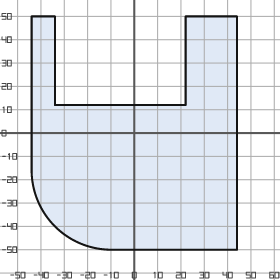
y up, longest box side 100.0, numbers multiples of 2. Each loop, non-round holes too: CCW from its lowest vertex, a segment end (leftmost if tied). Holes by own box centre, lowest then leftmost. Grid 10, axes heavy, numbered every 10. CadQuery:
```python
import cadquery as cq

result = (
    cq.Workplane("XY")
    .moveTo(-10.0, -50.0)
    .lineTo(44.0, -50.0)
    .lineTo(44.0, 50.0)
    .lineTo(22.0, 50.0)
    .lineTo(22.0, 12.0)
    .lineTo(-34.0, 12.0)
    .lineTo(-34.0, 50.0)
    .lineTo(-44.0, 50.0)
    .lineTo(-44.0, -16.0)
    .threePointArc((-34.0, -40.0), (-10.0, -50.0))
    .close()
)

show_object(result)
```